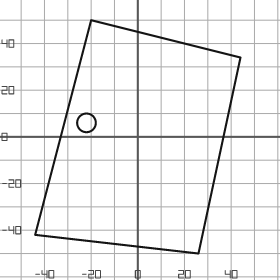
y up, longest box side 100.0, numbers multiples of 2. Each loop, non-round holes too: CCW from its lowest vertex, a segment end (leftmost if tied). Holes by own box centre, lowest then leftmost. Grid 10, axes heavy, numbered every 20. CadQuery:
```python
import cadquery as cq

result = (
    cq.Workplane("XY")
    .moveTo(26.0, -50.0)
    .lineTo(44.0, 34.0)
    .lineTo(-20.0, 50.0)
    .lineTo(-44.0, -42.0)
    .close()
    .moveTo(-22.0, 6.0)
    .circle(4.0)
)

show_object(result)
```